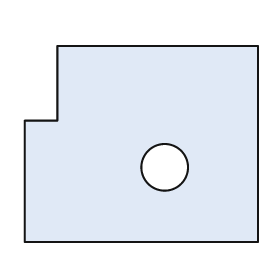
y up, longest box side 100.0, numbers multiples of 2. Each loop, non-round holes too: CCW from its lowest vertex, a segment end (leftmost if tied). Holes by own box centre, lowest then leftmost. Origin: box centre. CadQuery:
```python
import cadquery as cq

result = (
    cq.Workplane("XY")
    .moveTo(-50.0, -42.0)
    .lineTo(50.0, -42.0)
    .lineTo(50.0, 42.0)
    .lineTo(-36.0, 42.0)
    .lineTo(-36.0, 10.0)
    .lineTo(-50.0, 10.0)
    .close()
    .moveTo(10.0, -10.0)
    .circle(10.0)
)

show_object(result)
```